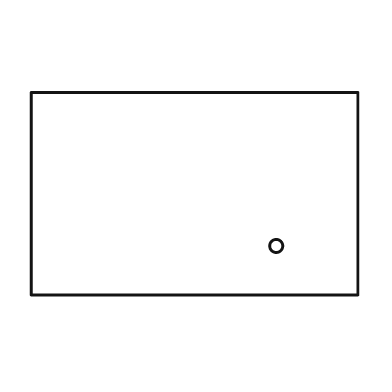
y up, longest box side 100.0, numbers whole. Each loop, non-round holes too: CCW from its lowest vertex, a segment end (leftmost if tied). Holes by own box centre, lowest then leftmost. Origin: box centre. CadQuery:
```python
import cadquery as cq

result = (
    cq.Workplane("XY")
    .moveTo(-50.0, -31.0)
    .lineTo(50.0, -31.0)
    .lineTo(50.0, 31.0)
    .lineTo(-50.0, 31.0)
    .close()
    .moveTo(25.0, -16.0)
    .circle(2.0)
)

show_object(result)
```